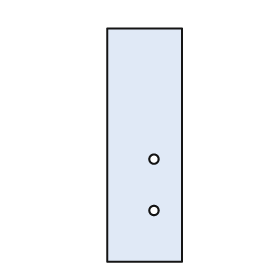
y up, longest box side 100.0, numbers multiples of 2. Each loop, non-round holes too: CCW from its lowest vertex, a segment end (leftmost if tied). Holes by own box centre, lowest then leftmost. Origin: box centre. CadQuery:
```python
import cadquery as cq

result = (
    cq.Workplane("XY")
    .moveTo(-16.0, -50.0)
    .lineTo(16.0, -50.0)
    .lineTo(16.0, 50.0)
    .lineTo(-16.0, 50.0)
    .close()
    .moveTo(4.0, -28.0)
    .circle(2.0)
    .moveTo(4.0, -6.0)
    .circle(2.0)
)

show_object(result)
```